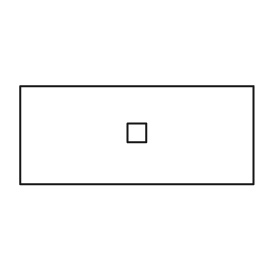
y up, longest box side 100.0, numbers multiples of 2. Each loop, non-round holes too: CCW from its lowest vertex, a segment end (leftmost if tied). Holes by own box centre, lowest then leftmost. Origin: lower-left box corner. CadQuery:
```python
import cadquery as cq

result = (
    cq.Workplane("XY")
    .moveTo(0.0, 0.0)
    .lineTo(100.0, 0.0)
    .lineTo(100.0, 42.0)
    .lineTo(0.0, 42.0)
    .close()
    .moveTo(46.0, 18.0)
    .lineTo(54.0, 18.0)
    .lineTo(54.0, 26.0)
    .lineTo(46.0, 26.0)
    .close()
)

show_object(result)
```